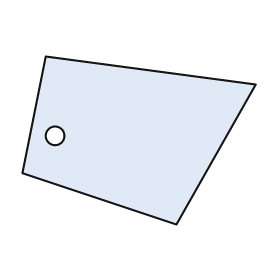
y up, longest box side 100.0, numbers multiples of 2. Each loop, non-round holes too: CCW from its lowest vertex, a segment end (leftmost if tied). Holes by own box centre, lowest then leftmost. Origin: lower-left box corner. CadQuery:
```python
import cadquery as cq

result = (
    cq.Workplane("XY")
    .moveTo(66.0, 0.0)
    .lineTo(100.0, 60.0)
    .lineTo(10.0, 72.0)
    .lineTo(0.0, 22.0)
    .close()
    .moveTo(14.0, 38.0)
    .circle(4.0)
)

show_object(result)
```